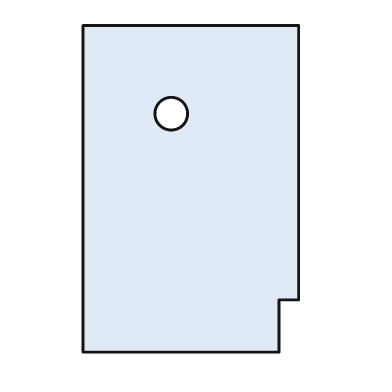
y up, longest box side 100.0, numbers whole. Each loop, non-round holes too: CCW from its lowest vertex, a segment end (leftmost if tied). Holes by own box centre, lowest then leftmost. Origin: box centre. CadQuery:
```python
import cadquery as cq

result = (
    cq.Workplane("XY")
    .moveTo(-33.0, -50.0)
    .lineTo(27.0, -50.0)
    .lineTo(27.0, -34.0)
    .lineTo(33.0, -34.0)
    .lineTo(33.0, 50.0)
    .lineTo(-33.0, 50.0)
    .close()
    .moveTo(-6.0, 23.0)
    .circle(5.0)
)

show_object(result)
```